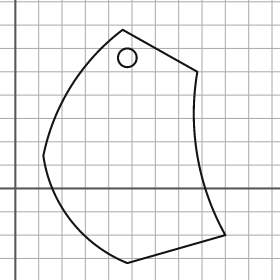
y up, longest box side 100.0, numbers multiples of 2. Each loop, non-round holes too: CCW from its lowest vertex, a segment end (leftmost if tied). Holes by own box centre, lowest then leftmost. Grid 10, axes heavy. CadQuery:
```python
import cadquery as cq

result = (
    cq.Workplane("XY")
    .moveTo(48.0, -32.0)
    .lineTo(90.0, -20.0)
    .threePointArc((78.0, 14.0), (78.0, 50.0))
    .lineTo(46.0, 68.0)
    .threePointArc((24.0, 44.0), (12.0, 14.0))
    .threePointArc((24.0, -14.0), (48.0, -32.0))
    .close()
    .moveTo(48.0, 56.0)
    .circle(4.0)
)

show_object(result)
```